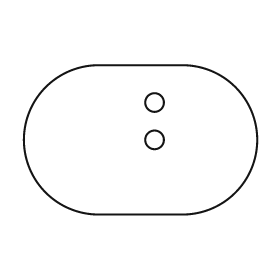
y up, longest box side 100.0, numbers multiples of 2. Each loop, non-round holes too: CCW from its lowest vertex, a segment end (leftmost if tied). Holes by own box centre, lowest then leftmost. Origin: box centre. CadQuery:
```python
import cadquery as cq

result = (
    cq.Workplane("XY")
    .moveTo(-18.0, -32.0)
    .lineTo(18.0, -32.0)
    .threePointArc((50.0, 0.0), (18.0, 32.0))
    .lineTo(-18.0, 32.0)
    .threePointArc((-50.0, 0.0), (-18.0, -32.0))
    .close()
    .moveTo(6.0, 0.0)
    .circle(4.0)
    .moveTo(6.0, 16.0)
    .circle(4.0)
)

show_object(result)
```